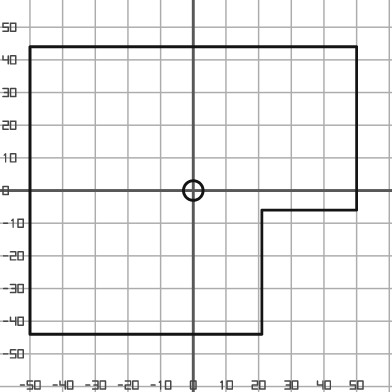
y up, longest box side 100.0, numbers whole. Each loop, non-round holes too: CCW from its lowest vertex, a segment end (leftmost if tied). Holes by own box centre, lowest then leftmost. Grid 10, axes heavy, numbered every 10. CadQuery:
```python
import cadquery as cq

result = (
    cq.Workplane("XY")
    .moveTo(-50.0, -44.0)
    .lineTo(21.0, -44.0)
    .lineTo(21.0, -6.0)
    .lineTo(50.0, -6.0)
    .lineTo(50.0, 44.0)
    .lineTo(-50.0, 44.0)
    .close()
    .moveTo(0.0, 0.0)
    .circle(3.0)
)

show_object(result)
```